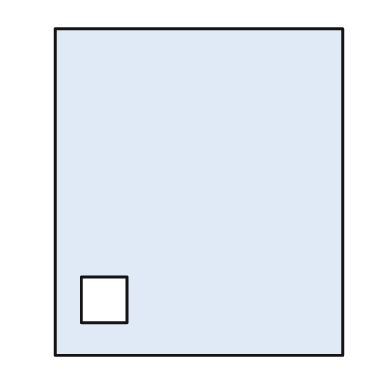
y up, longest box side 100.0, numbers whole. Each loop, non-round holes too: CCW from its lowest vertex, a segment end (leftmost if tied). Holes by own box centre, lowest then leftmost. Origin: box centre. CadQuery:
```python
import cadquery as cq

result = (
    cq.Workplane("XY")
    .moveTo(-44.0, -50.0)
    .lineTo(44.0, -50.0)
    .lineTo(44.0, 50.0)
    .lineTo(-44.0, 50.0)
    .close()
    .moveTo(-36.0, -40.0)
    .lineTo(-22.0, -40.0)
    .lineTo(-22.0, -26.0)
    .lineTo(-36.0, -26.0)
    .close()
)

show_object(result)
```